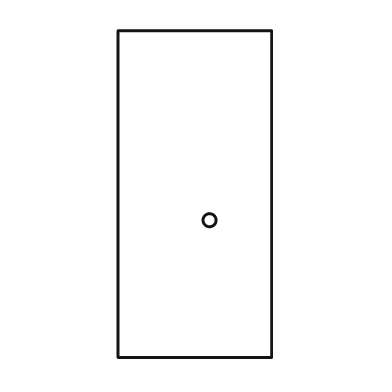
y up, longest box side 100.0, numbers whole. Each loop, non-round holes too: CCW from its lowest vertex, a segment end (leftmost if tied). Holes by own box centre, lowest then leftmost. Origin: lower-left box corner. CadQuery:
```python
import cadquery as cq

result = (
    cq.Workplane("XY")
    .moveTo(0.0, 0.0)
    .lineTo(47.0, 0.0)
    .lineTo(47.0, 100.0)
    .lineTo(0.0, 100.0)
    .close()
    .moveTo(28.0, 42.0)
    .circle(2.0)
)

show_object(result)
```